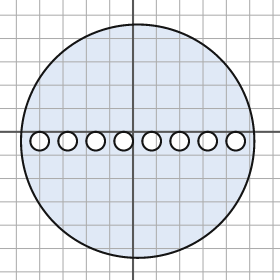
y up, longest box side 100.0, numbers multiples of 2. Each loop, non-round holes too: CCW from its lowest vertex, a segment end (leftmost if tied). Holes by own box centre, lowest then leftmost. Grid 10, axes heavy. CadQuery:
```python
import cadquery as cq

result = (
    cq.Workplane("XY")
    .moveTo(2.0, -4.0)
    .circle(50.0)
    .moveTo(-40.0, -4.0)
    .circle(4.0)
    .moveTo(-28.0, -4.0)
    .circle(4.0)
    .moveTo(-16.0, -4.0)
    .circle(4.0)
    .moveTo(-4.0, -4.0)
    .circle(4.0)
    .moveTo(8.0, -4.0)
    .circle(4.0)
    .moveTo(20.0, -4.0)
    .circle(4.0)
    .moveTo(32.0, -4.0)
    .circle(4.0)
    .moveTo(44.0, -4.0)
    .circle(4.0)
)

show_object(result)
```